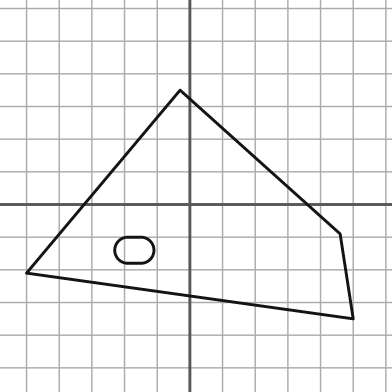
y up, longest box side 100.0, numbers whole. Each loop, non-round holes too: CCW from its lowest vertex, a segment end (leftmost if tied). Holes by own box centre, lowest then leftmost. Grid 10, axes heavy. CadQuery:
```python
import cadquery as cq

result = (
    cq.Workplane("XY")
    .moveTo(50.0, -35.0)
    .lineTo(46.0, -9.0)
    .lineTo(-3.0, 35.0)
    .lineTo(-50.0, -21.0)
    .close()
    .moveTo(-19.0, -18.0)
    .lineTo(-15.0, -18.0)
    .threePointArc((-11.0, -14.0), (-15.0, -10.0))
    .lineTo(-19.0, -10.0)
    .threePointArc((-23.0, -14.0), (-19.0, -18.0))
    .close()
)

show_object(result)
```